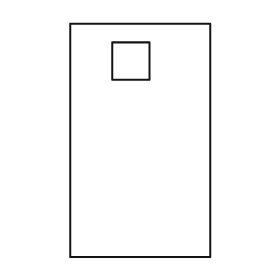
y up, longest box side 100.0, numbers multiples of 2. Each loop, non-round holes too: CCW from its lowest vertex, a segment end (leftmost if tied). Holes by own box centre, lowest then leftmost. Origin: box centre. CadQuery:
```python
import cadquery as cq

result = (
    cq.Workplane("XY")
    .moveTo(-30.0, -50.0)
    .lineTo(30.0, -50.0)
    .lineTo(30.0, 50.0)
    .lineTo(-30.0, 50.0)
    .close()
    .moveTo(-12.0, 26.0)
    .lineTo(4.0, 26.0)
    .lineTo(4.0, 42.0)
    .lineTo(-12.0, 42.0)
    .close()
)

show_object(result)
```